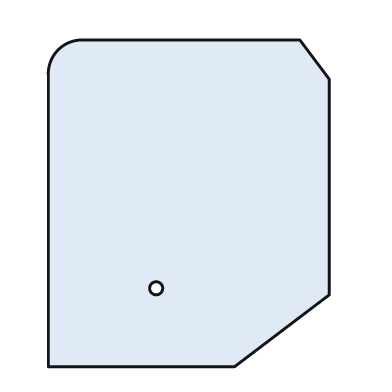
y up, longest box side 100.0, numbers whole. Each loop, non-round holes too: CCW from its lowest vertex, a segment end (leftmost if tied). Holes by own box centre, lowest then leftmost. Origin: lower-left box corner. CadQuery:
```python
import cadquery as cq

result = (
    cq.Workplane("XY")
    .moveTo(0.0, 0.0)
    .lineTo(57.0, 0.0)
    .lineTo(86.0, 22.0)
    .lineTo(86.0, 88.0)
    .lineTo(77.0, 100.0)
    .lineTo(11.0, 100.0)
    .threePointArc((3.0, 97.0), (0.0, 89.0))
    .close()
    .moveTo(33.0, 24.0)
    .circle(2.0)
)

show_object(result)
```